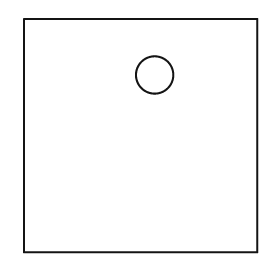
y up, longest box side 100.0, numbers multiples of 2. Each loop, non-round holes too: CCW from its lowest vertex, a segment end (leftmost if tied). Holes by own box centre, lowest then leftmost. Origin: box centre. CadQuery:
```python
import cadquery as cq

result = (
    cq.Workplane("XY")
    .moveTo(-50.0, -50.0)
    .lineTo(50.0, -50.0)
    .lineTo(50.0, 50.0)
    .lineTo(-50.0, 50.0)
    .close()
    .moveTo(6.0, 26.0)
    .circle(8.0)
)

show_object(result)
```